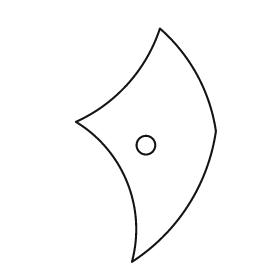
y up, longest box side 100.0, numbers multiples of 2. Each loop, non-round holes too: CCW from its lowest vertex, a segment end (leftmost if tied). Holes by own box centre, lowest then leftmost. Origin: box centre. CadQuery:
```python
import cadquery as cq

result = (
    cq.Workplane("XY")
    .moveTo(-6.0, -50.0)
    .threePointArc((18.0, -26.0), (30.0, 6.0))
    .threePointArc((22.0, 30.0), (6.0, 50.0))
    .threePointArc((-8.0, 26.0), (-30.0, 10.0))
    .threePointArc((-8.0, -16.0), (-6.0, -50.0))
    .close()
    .moveTo(0.0, 0.0)
    .circle(4.0)
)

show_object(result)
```